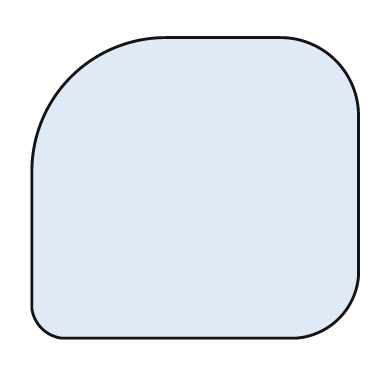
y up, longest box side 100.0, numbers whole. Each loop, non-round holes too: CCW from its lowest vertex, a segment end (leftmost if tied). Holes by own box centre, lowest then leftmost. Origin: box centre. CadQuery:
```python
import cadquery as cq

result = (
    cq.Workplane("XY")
    .moveTo(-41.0, -46.0)
    .lineTo(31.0, -46.0)
    .threePointArc((44.0, -40.0), (50.0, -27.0))
    .lineTo(50.0, 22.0)
    .threePointArc((43.0, 39.0), (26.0, 46.0))
    .lineTo(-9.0, 46.0)
    .threePointArc((-38.0, 34.0), (-50.0, 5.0))
    .lineTo(-50.0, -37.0)
    .threePointArc((-47.0, -43.0), (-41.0, -46.0))
    .close()
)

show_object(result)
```